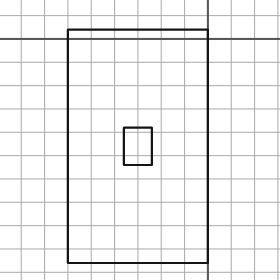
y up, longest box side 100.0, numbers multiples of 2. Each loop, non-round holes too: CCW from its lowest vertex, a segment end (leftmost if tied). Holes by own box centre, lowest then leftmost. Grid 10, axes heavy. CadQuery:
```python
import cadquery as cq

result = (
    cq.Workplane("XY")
    .moveTo(-60.0, -96.0)
    .lineTo(0.0, -96.0)
    .lineTo(0.0, 4.0)
    .lineTo(-60.0, 4.0)
    .close()
    .moveTo(-36.0, -54.0)
    .lineTo(-24.0, -54.0)
    .lineTo(-24.0, -38.0)
    .lineTo(-36.0, -38.0)
    .close()
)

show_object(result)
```